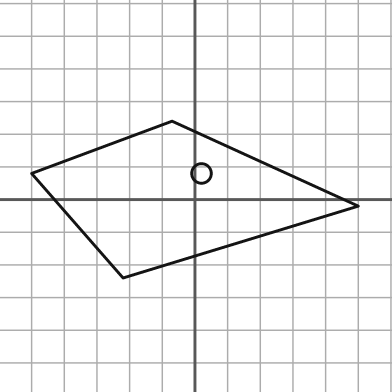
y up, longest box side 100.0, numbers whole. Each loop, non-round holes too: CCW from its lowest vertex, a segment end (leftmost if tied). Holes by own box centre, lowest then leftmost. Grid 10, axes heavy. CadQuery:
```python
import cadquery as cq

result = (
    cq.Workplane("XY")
    .moveTo(-22.0, -24.0)
    .lineTo(50.0, -2.0)
    .lineTo(-7.0, 24.0)
    .lineTo(-50.0, 8.0)
    .close()
    .moveTo(2.0, 8.0)
    .circle(3.0)
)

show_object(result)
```